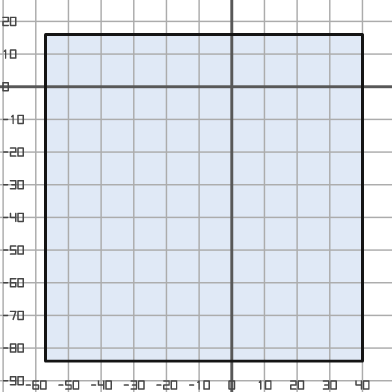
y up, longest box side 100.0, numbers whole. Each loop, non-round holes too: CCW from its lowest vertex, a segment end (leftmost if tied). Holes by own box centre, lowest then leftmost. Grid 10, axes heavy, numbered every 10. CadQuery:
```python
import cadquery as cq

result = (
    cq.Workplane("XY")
    .moveTo(-57.0, -84.0)
    .lineTo(40.0, -84.0)
    .lineTo(40.0, 16.0)
    .lineTo(-57.0, 16.0)
    .close()
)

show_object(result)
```